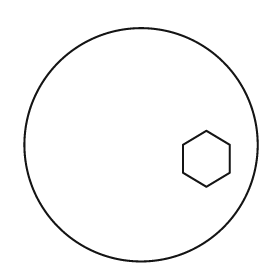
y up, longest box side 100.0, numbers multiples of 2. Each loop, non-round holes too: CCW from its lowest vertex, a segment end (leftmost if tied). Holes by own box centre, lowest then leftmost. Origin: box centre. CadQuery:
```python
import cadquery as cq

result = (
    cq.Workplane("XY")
    .moveTo(0.0, 0.0)
    .circle(50.0)
    .moveTo(28.0, -18.0)
    .lineTo(38.0, -12.0)
    .lineTo(38.0, 0.0)
    .lineTo(28.0, 6.0)
    .lineTo(18.0, 0.0)
    .lineTo(18.0, -12.0)
    .close()
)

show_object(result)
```